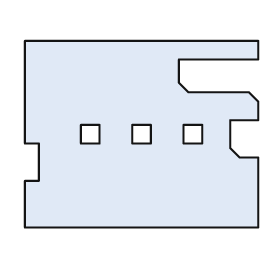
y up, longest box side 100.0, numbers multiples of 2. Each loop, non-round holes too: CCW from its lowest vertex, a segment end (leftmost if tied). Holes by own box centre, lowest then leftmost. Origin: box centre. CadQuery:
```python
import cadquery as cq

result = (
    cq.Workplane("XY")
    .moveTo(-50.0, -40.0)
    .lineTo(50.0, -40.0)
    .lineTo(50.0, -10.0)
    .lineTo(42.0, -10.0)
    .lineTo(38.0, -6.0)
    .lineTo(38.0, 6.0)
    .lineTo(50.0, 6.0)
    .lineTo(50.0, 14.0)
    .lineTo(46.0, 18.0)
    .lineTo(20.0, 18.0)
    .lineTo(16.0, 22.0)
    .lineTo(16.0, 32.0)
    .lineTo(50.0, 32.0)
    .lineTo(50.0, 40.0)
    .lineTo(-50.0, 40.0)
    .lineTo(-50.0, -4.0)
    .lineTo(-44.0, -4.0)
    .lineTo(-44.0, -20.0)
    .lineTo(-50.0, -20.0)
    .close()
    .moveTo(-26.0, -4.0)
    .lineTo(-18.0, -4.0)
    .lineTo(-18.0, 4.0)
    .lineTo(-26.0, 4.0)
    .close()
    .moveTo(-4.0, -4.0)
    .lineTo(4.0, -4.0)
    .lineTo(4.0, 4.0)
    .lineTo(-4.0, 4.0)
    .close()
    .moveTo(18.0, -4.0)
    .lineTo(26.0, -4.0)
    .lineTo(26.0, 4.0)
    .lineTo(18.0, 4.0)
    .close()
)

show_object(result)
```